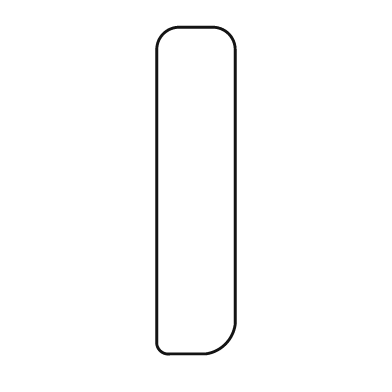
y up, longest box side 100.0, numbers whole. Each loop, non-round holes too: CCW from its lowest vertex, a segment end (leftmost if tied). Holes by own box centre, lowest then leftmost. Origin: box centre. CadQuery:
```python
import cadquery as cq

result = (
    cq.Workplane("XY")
    .moveTo(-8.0, -50.0)
    .lineTo(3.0, -50.0)
    .threePointArc((9.0, -47.0), (12.0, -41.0))
    .lineTo(12.0, 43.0)
    .threePointArc((10.0, 48.0), (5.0, 50.0))
    .lineTo(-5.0, 50.0)
    .threePointArc((-10.0, 48.0), (-12.0, 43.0))
    .lineTo(-12.0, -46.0)
    .threePointArc((-11.0, -49.0), (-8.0, -50.0))
    .close()
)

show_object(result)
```